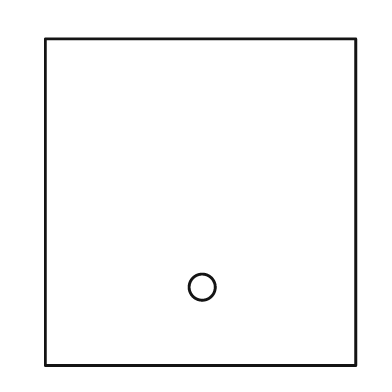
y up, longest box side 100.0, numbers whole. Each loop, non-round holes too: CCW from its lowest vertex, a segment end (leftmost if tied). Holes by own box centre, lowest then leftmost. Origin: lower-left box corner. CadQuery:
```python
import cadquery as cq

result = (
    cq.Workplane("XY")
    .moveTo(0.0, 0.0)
    .lineTo(95.0, 0.0)
    .lineTo(95.0, 100.0)
    .lineTo(0.0, 100.0)
    .close()
    .moveTo(48.0, 24.0)
    .circle(4.0)
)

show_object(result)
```